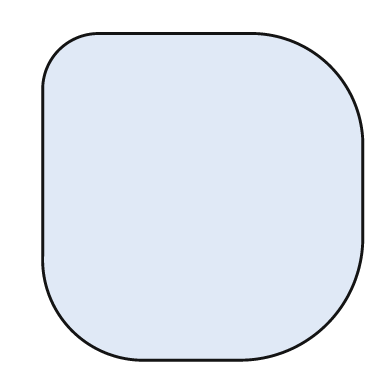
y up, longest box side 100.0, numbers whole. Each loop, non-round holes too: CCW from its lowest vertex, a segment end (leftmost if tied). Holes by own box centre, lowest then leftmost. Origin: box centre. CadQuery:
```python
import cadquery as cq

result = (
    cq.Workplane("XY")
    .moveTo(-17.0, -50.0)
    .lineTo(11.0, -50.0)
    .threePointArc((38.0, -39.0), (49.0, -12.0))
    .lineTo(49.0, 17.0)
    .threePointArc((39.0, 40.0), (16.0, 50.0))
    .lineTo(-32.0, 50.0)
    .threePointArc((-44.0, 45.0), (-49.0, 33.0))
    .lineTo(-49.0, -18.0)
    .threePointArc((-40.0, -41.0), (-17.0, -50.0))
    .close()
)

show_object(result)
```